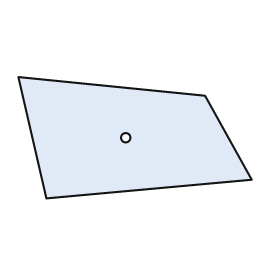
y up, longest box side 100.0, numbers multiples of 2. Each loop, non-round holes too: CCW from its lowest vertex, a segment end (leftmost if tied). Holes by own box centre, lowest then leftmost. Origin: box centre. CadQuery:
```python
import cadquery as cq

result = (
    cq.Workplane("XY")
    .moveTo(-38.0, -26.0)
    .lineTo(50.0, -18.0)
    .lineTo(30.0, 18.0)
    .lineTo(-50.0, 26.0)
    .close()
    .moveTo(-4.0, 0.0)
    .circle(2.0)
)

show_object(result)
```